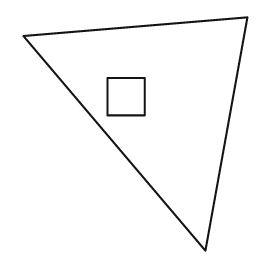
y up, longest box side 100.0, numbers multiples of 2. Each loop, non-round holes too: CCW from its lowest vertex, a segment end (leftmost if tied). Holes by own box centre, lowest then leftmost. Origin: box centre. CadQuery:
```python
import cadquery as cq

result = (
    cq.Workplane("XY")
    .moveTo(30.0, -50.0)
    .lineTo(48.0, 50.0)
    .lineTo(-48.0, 42.0)
    .close()
    .moveTo(-12.0, 8.0)
    .lineTo(4.0, 8.0)
    .lineTo(4.0, 24.0)
    .lineTo(-12.0, 24.0)
    .close()
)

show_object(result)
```